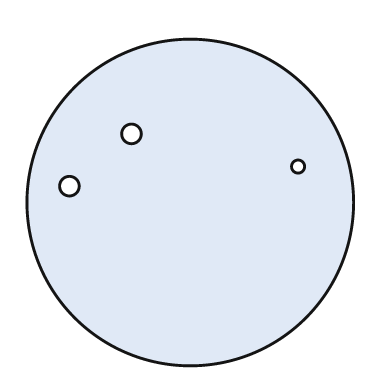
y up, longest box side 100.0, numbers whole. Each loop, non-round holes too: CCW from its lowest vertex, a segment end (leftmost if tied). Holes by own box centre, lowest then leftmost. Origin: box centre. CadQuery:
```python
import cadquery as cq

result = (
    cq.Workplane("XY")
    .moveTo(0.0, 0.0)
    .circle(50.0)
    .moveTo(-37.0, 5.0)
    .circle(3.0)
    .moveTo(33.0, 11.0)
    .circle(2.0)
    .moveTo(-18.0, 21.0)
    .circle(3.0)
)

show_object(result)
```